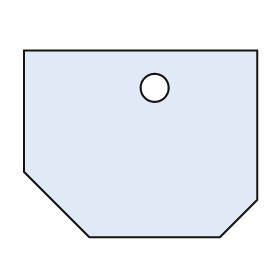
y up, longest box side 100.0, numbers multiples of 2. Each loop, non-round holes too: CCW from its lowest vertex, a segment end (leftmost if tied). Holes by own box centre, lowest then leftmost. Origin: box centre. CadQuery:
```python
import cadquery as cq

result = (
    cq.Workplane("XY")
    .moveTo(-22.0, -40.0)
    .lineTo(34.0, -40.0)
    .lineTo(50.0, -24.0)
    .lineTo(50.0, 40.0)
    .lineTo(-50.0, 40.0)
    .lineTo(-50.0, -12.0)
    .close()
    .moveTo(6.0, 24.0)
    .circle(6.0)
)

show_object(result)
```